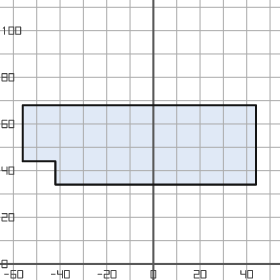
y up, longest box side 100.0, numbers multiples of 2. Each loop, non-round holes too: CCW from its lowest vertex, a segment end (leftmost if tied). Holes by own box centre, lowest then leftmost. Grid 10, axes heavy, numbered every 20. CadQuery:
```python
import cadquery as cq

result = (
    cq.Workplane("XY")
    .moveTo(-42.0, 34.0)
    .lineTo(44.0, 34.0)
    .lineTo(44.0, 68.0)
    .lineTo(-56.0, 68.0)
    .lineTo(-56.0, 44.0)
    .lineTo(-42.0, 44.0)
    .close()
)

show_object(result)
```